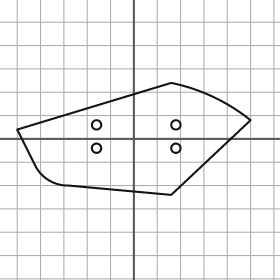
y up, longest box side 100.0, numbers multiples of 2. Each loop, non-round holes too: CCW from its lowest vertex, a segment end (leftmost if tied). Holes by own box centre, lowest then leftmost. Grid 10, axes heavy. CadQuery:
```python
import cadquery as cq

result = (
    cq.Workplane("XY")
    .moveTo(16.0, -24.0)
    .lineTo(50.0, 8.0)
    .threePointArc((34.0, 18.0), (16.0, 24.0))
    .lineTo(-50.0, 4.0)
    .lineTo(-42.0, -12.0)
    .threePointArc((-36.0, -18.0), (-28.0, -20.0))
    .close()
    .moveTo(-16.0, -4.0)
    .circle(2.0)
    .moveTo(18.0, -4.0)
    .circle(2.0)
    .moveTo(-16.0, 6.0)
    .circle(2.0)
    .moveTo(18.0, 6.0)
    .circle(2.0)
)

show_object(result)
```